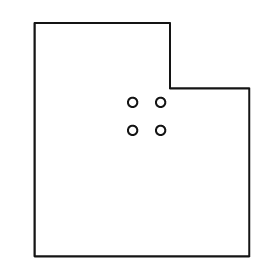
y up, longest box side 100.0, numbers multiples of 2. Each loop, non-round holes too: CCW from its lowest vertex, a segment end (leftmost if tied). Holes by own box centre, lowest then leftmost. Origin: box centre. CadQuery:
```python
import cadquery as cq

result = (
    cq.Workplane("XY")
    .moveTo(-46.0, -50.0)
    .lineTo(46.0, -50.0)
    .lineTo(46.0, 22.0)
    .lineTo(12.0, 22.0)
    .lineTo(12.0, 50.0)
    .lineTo(-46.0, 50.0)
    .close()
    .moveTo(-4.0, 4.0)
    .circle(2.0)
    .moveTo(8.0, 4.0)
    .circle(2.0)
    .moveTo(-4.0, 16.0)
    .circle(2.0)
    .moveTo(8.0, 16.0)
    .circle(2.0)
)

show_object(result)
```